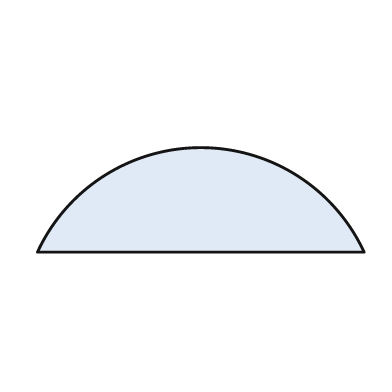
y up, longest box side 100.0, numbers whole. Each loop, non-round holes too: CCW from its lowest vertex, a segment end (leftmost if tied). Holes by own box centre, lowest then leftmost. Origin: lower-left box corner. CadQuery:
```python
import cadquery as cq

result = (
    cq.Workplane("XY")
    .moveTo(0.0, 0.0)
    .lineTo(100.0, 0.0)
    .threePointArc((50.0, 32.0), (0.0, 0.0))
    .close()
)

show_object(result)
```